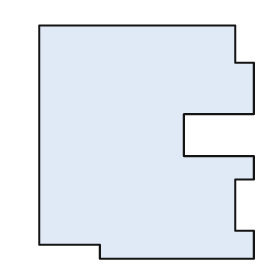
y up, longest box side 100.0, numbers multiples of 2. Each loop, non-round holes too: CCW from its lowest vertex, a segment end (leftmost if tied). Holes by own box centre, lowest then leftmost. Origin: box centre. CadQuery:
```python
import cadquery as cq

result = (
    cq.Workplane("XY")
    .moveTo(-20.0, -50.0)
    .lineTo(46.0, -50.0)
    .lineTo(46.0, -38.0)
    .lineTo(38.0, -38.0)
    .lineTo(38.0, -16.0)
    .lineTo(46.0, -16.0)
    .lineTo(46.0, -6.0)
    .lineTo(16.0, -6.0)
    .lineTo(16.0, 12.0)
    .lineTo(46.0, 12.0)
    .lineTo(46.0, 34.0)
    .lineTo(38.0, 34.0)
    .lineTo(38.0, 50.0)
    .lineTo(-46.0, 50.0)
    .lineTo(-46.0, -44.0)
    .lineTo(-20.0, -44.0)
    .close()
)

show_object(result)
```